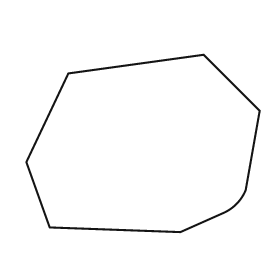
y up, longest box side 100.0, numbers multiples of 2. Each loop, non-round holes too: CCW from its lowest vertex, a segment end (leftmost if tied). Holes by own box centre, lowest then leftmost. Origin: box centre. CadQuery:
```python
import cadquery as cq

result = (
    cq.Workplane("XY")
    .moveTo(16.0, -38.0)
    .lineTo(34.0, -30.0)
    .threePointArc((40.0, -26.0), (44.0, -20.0))
    .lineTo(50.0, 14.0)
    .lineTo(26.0, 38.0)
    .lineTo(-32.0, 30.0)
    .lineTo(-50.0, -8.0)
    .lineTo(-40.0, -36.0)
    .close()
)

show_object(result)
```